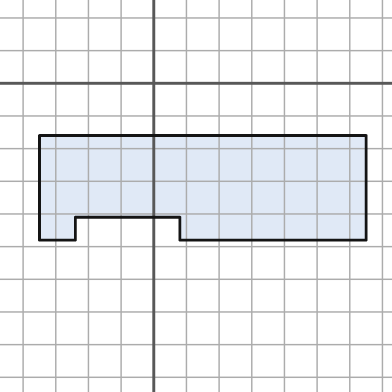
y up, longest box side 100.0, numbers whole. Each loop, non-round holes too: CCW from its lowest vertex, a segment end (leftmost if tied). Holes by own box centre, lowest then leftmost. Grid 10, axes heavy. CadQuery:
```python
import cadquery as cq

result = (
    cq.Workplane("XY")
    .moveTo(-35.0, -48.0)
    .lineTo(-24.0, -48.0)
    .lineTo(-24.0, -41.0)
    .lineTo(8.0, -41.0)
    .lineTo(8.0, -48.0)
    .lineTo(65.0, -48.0)
    .lineTo(65.0, -16.0)
    .lineTo(-35.0, -16.0)
    .close()
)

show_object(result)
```